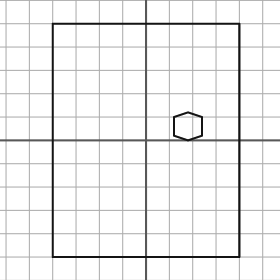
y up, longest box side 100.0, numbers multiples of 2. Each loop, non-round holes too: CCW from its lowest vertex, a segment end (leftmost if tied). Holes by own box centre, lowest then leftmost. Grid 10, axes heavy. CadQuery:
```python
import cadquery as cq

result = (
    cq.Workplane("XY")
    .moveTo(-40.0, -50.0)
    .lineTo(40.0, -50.0)
    .lineTo(40.0, 50.0)
    .lineTo(-40.0, 50.0)
    .close()
    .moveTo(18.0, 0.0)
    .lineTo(24.0, 2.0)
    .lineTo(24.0, 10.0)
    .lineTo(18.0, 12.0)
    .lineTo(12.0, 10.0)
    .lineTo(12.0, 2.0)
    .close()
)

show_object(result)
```